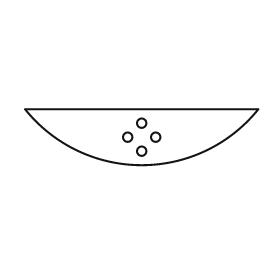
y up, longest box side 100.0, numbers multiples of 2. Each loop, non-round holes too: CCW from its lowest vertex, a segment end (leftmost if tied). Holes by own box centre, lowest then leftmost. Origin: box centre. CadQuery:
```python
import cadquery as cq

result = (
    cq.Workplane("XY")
    .moveTo(-50.0, 12.0)
    .threePointArc((0.0, -12.0), (50.0, 12.0))
    .close()
    .moveTo(0.0, -6.0)
    .circle(2.0)
    .moveTo(-6.0, 0.0)
    .circle(2.0)
    .moveTo(6.0, 0.0)
    .circle(2.0)
    .moveTo(0.0, 6.0)
    .circle(2.0)
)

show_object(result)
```